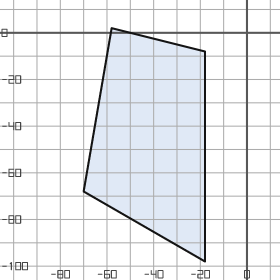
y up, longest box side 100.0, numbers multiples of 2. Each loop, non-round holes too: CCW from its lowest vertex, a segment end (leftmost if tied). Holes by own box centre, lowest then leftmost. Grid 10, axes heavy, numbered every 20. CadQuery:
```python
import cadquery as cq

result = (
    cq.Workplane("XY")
    .moveTo(-18.0, -98.0)
    .lineTo(-18.0, -8.0)
    .lineTo(-58.0, 2.0)
    .lineTo(-70.0, -68.0)
    .close()
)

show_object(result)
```